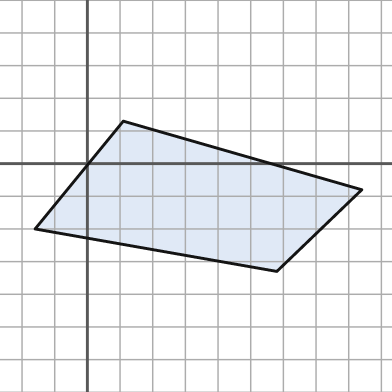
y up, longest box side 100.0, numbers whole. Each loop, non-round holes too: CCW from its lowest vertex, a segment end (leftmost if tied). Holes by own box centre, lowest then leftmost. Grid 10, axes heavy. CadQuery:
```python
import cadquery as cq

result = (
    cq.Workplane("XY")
    .moveTo(58.0, -33.0)
    .lineTo(84.0, -8.0)
    .lineTo(11.0, 13.0)
    .lineTo(-16.0, -20.0)
    .close()
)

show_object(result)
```